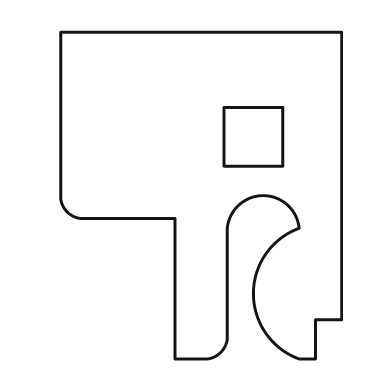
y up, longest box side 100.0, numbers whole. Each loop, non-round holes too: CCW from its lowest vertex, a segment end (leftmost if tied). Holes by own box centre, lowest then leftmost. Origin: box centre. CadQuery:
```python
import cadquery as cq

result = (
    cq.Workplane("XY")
    .moveTo(-8.0, -50.0)
    .lineTo(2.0, -50.0)
    .threePointArc((6.0, -48.0), (8.0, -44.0))
    .lineTo(8.0, -10.0)
    .threePointArc((19.0, 0.0), (30.0, -10.0))
    .threePointArc((16.0, -30.0), (30.0, -50.0))
    .lineTo(35.0, -50.0)
    .lineTo(35.0, -38.0)
    .lineTo(43.0, -38.0)
    .lineTo(43.0, 50.0)
    .lineTo(-43.0, 50.0)
    .lineTo(-43.0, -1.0)
    .threePointArc((-41.0, -5.0), (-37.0, -7.0))
    .lineTo(-8.0, -7.0)
    .close()
    .moveTo(7.0, 9.0)
    .lineTo(25.0, 9.0)
    .lineTo(25.0, 27.0)
    .lineTo(7.0, 27.0)
    .close()
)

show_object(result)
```